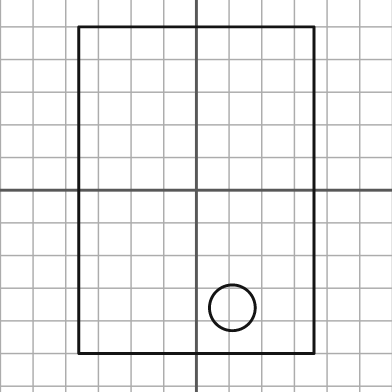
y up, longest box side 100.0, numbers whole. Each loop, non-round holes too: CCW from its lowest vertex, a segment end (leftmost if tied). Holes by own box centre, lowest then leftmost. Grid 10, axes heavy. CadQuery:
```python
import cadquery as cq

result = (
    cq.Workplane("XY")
    .moveTo(-36.0, -50.0)
    .lineTo(36.0, -50.0)
    .lineTo(36.0, 50.0)
    .lineTo(-36.0, 50.0)
    .close()
    .moveTo(11.0, -36.0)
    .circle(7.0)
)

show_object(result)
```